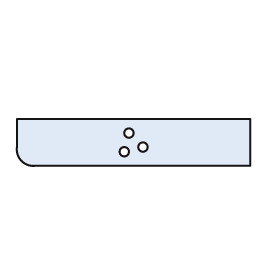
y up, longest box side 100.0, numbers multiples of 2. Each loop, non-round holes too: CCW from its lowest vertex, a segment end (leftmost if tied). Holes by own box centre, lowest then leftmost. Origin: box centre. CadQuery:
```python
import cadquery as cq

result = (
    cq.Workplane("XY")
    .moveTo(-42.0, -10.0)
    .lineTo(50.0, -10.0)
    .lineTo(50.0, 10.0)
    .lineTo(-50.0, 10.0)
    .lineTo(-50.0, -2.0)
    .threePointArc((-48.0, -8.0), (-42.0, -10.0))
    .close()
    .moveTo(-4.0, -4.0)
    .circle(2.0)
    .moveTo(4.0, -2.0)
    .circle(2.0)
    .moveTo(-2.0, 4.0)
    .circle(2.0)
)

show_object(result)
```